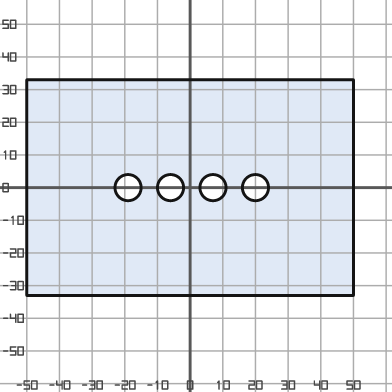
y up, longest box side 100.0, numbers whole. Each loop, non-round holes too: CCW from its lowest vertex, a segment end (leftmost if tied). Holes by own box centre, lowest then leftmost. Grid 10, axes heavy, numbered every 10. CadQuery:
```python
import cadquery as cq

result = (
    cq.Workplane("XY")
    .moveTo(-50.0, -33.0)
    .lineTo(50.0, -33.0)
    .lineTo(50.0, 33.0)
    .lineTo(-50.0, 33.0)
    .close()
    .moveTo(-19.0, 0.0)
    .circle(4.0)
    .moveTo(-6.0, 0.0)
    .circle(4.0)
    .moveTo(7.0, 0.0)
    .circle(4.0)
    .moveTo(20.0, 0.0)
    .circle(4.0)
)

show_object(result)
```